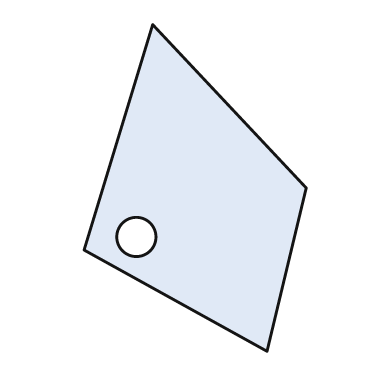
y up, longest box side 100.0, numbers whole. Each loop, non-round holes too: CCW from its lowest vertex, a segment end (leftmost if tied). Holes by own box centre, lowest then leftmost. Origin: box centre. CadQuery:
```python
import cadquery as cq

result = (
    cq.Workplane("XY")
    .moveTo(22.0, -50.0)
    .lineTo(34.0, 0.0)
    .lineTo(-13.0, 50.0)
    .lineTo(-34.0, -19.0)
    .close()
    .moveTo(-18.0, -15.0)
    .circle(6.0)
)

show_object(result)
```